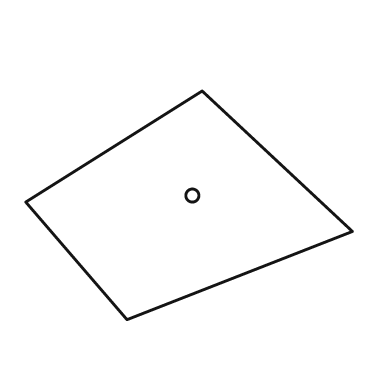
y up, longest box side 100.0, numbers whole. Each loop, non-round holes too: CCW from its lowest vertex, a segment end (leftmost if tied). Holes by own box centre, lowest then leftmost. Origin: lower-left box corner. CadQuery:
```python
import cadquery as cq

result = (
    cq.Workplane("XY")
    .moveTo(31.0, 0.0)
    .lineTo(100.0, 27.0)
    .lineTo(54.0, 70.0)
    .lineTo(0.0, 36.0)
    .close()
    .moveTo(51.0, 38.0)
    .circle(2.0)
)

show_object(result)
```